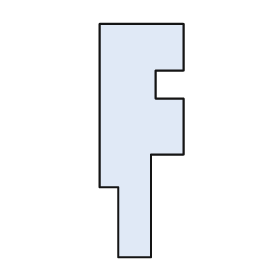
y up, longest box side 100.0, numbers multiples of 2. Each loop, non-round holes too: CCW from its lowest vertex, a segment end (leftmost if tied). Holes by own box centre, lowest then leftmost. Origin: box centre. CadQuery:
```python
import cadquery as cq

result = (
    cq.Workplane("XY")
    .moveTo(-10.0, -50.0)
    .lineTo(4.0, -50.0)
    .lineTo(4.0, -6.0)
    .lineTo(18.0, -6.0)
    .lineTo(18.0, 18.0)
    .lineTo(6.0, 18.0)
    .lineTo(6.0, 30.0)
    .lineTo(18.0, 30.0)
    .lineTo(18.0, 50.0)
    .lineTo(-18.0, 50.0)
    .lineTo(-18.0, -20.0)
    .lineTo(-10.0, -20.0)
    .close()
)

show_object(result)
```